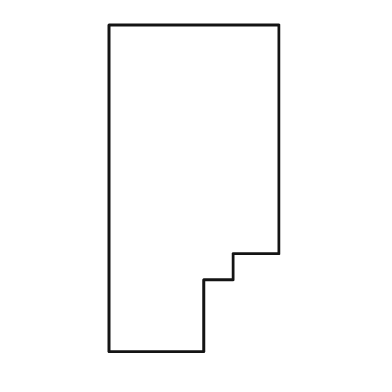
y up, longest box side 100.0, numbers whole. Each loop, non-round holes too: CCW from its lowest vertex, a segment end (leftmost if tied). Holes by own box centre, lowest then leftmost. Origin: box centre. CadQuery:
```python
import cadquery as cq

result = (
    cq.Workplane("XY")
    .moveTo(-26.0, -50.0)
    .lineTo(3.0, -50.0)
    .lineTo(3.0, -28.0)
    .lineTo(12.0, -28.0)
    .lineTo(12.0, -20.0)
    .lineTo(26.0, -20.0)
    .lineTo(26.0, 50.0)
    .lineTo(-26.0, 50.0)
    .close()
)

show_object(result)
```